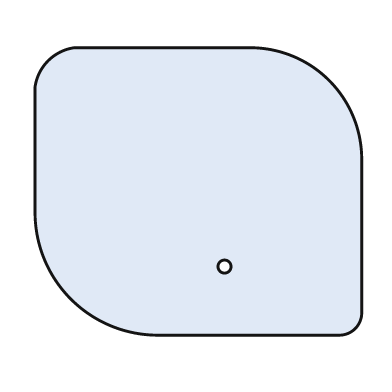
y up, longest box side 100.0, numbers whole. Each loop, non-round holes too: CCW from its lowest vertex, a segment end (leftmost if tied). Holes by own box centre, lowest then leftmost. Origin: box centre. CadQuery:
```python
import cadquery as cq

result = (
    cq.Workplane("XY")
    .moveTo(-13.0, -44.0)
    .lineTo(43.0, -44.0)
    .threePointArc((48.0, -42.0), (50.0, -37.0))
    .lineTo(50.0, 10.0)
    .threePointArc((40.0, 34.0), (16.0, 44.0))
    .lineTo(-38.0, 44.0)
    .threePointArc((-46.0, 40.0), (-50.0, 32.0))
    .lineTo(-50.0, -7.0)
    .threePointArc((-39.0, -33.0), (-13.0, -44.0))
    .close()
    .moveTo(8.0, -23.0)
    .circle(2.0)
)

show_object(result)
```